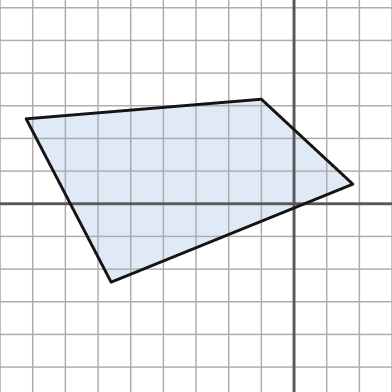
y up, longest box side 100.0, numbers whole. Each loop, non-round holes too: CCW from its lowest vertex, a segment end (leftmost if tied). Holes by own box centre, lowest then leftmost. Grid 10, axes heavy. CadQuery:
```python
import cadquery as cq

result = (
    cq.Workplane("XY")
    .moveTo(-56.0, -24.0)
    .lineTo(18.0, 6.0)
    .lineTo(-10.0, 32.0)
    .lineTo(-82.0, 26.0)
    .close()
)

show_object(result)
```